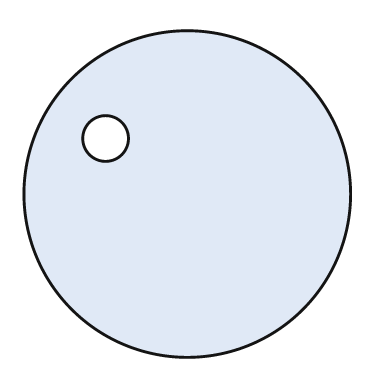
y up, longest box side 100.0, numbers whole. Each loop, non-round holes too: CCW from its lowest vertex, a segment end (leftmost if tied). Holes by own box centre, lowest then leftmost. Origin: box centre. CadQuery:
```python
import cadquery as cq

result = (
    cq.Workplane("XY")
    .moveTo(0.0, 0.0)
    .circle(50.0)
    .moveTo(-25.0, 17.0)
    .circle(7.0)
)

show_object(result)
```